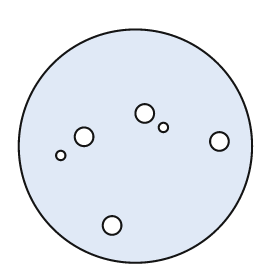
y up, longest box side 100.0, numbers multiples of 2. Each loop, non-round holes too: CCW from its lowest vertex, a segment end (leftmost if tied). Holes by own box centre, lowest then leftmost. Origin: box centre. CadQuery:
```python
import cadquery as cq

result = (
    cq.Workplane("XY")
    .moveTo(0.0, 0.0)
    .circle(50.0)
    .moveTo(-10.0, -34.0)
    .circle(4.0)
    .moveTo(-32.0, -4.0)
    .circle(2.0)
    .moveTo(36.0, 2.0)
    .circle(4.0)
    .moveTo(-22.0, 4.0)
    .circle(4.0)
    .moveTo(12.0, 8.0)
    .circle(2.0)
    .moveTo(4.0, 14.0)
    .circle(4.0)
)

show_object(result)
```